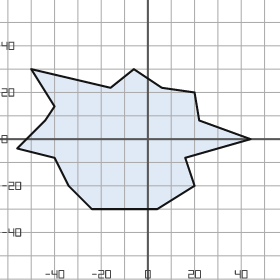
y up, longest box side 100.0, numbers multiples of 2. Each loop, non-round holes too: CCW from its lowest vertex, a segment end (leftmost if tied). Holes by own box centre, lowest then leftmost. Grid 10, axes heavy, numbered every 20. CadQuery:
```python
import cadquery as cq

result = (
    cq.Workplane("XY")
    .moveTo(-24.0, -30.0)
    .lineTo(4.0, -30.0)
    .lineTo(20.0, -20.0)
    .lineTo(16.0, -8.0)
    .lineTo(44.0, 0.0)
    .lineTo(22.0, 8.0)
    .lineTo(20.0, 20.0)
    .lineTo(6.0, 22.0)
    .lineTo(-6.0, 30.0)
    .lineTo(-16.0, 22.0)
    .lineTo(-50.0, 30.0)
    .lineTo(-40.0, 14.0)
    .lineTo(-44.0, 8.0)
    .lineTo(-56.0, -4.0)
    .lineTo(-40.0, -8.0)
    .lineTo(-34.0, -20.0)
    .close()
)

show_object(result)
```